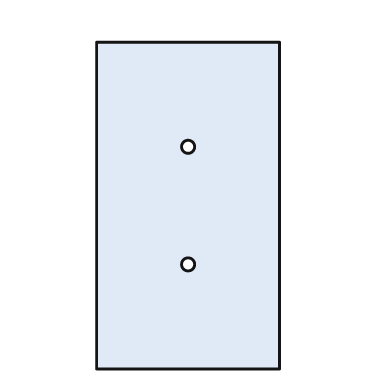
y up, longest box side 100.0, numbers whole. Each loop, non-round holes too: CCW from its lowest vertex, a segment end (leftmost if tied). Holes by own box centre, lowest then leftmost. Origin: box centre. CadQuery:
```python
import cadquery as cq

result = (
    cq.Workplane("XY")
    .moveTo(-28.0, -50.0)
    .lineTo(28.0, -50.0)
    .lineTo(28.0, 50.0)
    .lineTo(-28.0, 50.0)
    .close()
    .moveTo(0.0, -18.0)
    .circle(2.0)
    .moveTo(0.0, 18.0)
    .circle(2.0)
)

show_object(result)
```